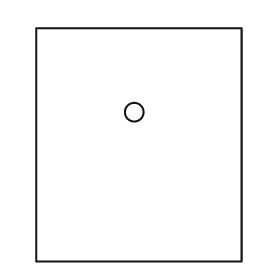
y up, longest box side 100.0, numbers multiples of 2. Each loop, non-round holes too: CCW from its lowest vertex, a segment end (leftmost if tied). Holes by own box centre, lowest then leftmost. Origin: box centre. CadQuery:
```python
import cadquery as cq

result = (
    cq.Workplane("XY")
    .moveTo(-44.0, -50.0)
    .lineTo(44.0, -50.0)
    .lineTo(44.0, 50.0)
    .lineTo(-44.0, 50.0)
    .close()
    .moveTo(-2.0, 14.0)
    .circle(4.0)
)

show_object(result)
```